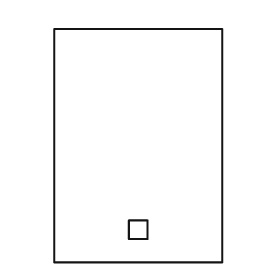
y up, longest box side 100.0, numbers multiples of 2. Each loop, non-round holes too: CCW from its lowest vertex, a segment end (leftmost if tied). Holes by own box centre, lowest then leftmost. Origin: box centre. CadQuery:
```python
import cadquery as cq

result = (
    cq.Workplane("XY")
    .moveTo(-36.0, -50.0)
    .lineTo(36.0, -50.0)
    .lineTo(36.0, 50.0)
    .lineTo(-36.0, 50.0)
    .close()
    .moveTo(-4.0, -40.0)
    .lineTo(4.0, -40.0)
    .lineTo(4.0, -32.0)
    .lineTo(-4.0, -32.0)
    .close()
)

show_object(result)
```